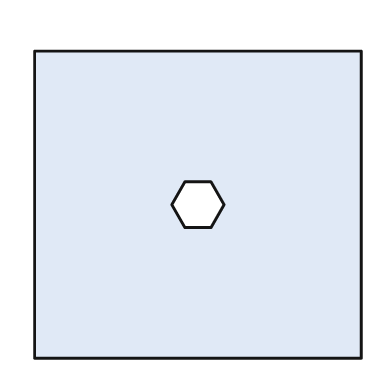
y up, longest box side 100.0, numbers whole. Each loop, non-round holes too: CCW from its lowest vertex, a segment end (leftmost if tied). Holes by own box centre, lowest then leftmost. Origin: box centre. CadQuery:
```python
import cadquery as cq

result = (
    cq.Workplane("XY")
    .moveTo(-50.0, -47.0)
    .lineTo(50.0, -47.0)
    .lineTo(50.0, 47.0)
    .lineTo(-50.0, 47.0)
    .close()
    .moveTo(-4.0, -7.0)
    .lineTo(4.0, -7.0)
    .lineTo(8.0, 0.0)
    .lineTo(4.0, 7.0)
    .lineTo(-4.0, 7.0)
    .lineTo(-8.0, 0.0)
    .close()
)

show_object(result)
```